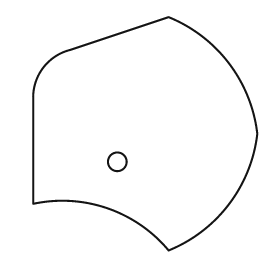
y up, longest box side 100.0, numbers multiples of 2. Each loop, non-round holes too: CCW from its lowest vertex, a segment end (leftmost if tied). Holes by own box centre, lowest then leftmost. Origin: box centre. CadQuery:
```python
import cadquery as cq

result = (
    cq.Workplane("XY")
    .moveTo(10.0, -50.0)
    .threePointArc((36.0, -30.0), (48.0, 0.0))
    .threePointArc((36.0, 30.0), (10.0, 50.0))
    .lineTo(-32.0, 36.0)
    .threePointArc((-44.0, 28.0), (-48.0, 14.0))
    .lineTo(-48.0, -30.0)
    .threePointArc((-16.0, -32.0), (10.0, -50.0))
    .close()
    .moveTo(-12.0, -12.0)
    .circle(4.0)
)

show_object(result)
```